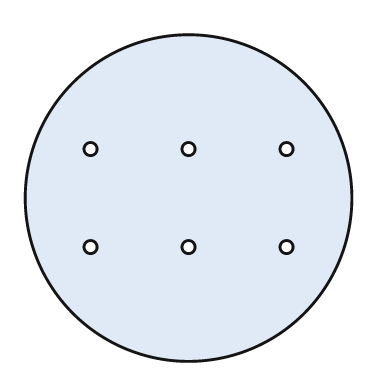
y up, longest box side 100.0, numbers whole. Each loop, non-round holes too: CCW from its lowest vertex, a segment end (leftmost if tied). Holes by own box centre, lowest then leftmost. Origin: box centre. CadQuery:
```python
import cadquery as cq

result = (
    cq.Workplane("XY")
    .moveTo(0.0, 0.0)
    .circle(50.0)
    .moveTo(-30.0, -15.0)
    .circle(2.0)
    .moveTo(0.0, -15.0)
    .circle(2.0)
    .moveTo(30.0, -15.0)
    .circle(2.0)
    .moveTo(-30.0, 15.0)
    .circle(2.0)
    .moveTo(0.0, 15.0)
    .circle(2.0)
    .moveTo(30.0, 15.0)
    .circle(2.0)
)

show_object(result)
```